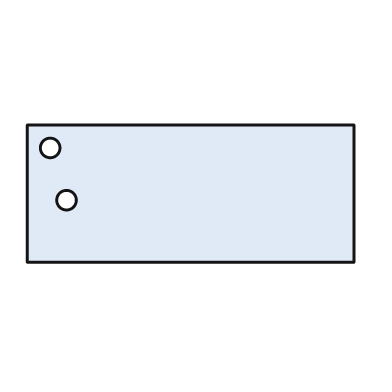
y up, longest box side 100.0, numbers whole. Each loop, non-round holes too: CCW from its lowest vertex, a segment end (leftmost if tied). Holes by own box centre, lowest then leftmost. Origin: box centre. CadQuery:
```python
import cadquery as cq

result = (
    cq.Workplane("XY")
    .moveTo(-50.0, -21.0)
    .lineTo(50.0, -21.0)
    .lineTo(50.0, 21.0)
    .lineTo(-50.0, 21.0)
    .close()
    .moveTo(-38.0, -2.0)
    .circle(3.0)
    .moveTo(-43.0, 14.0)
    .circle(3.0)
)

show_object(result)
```